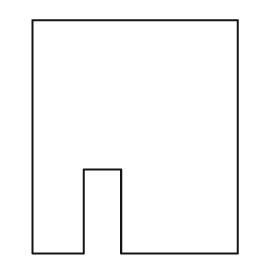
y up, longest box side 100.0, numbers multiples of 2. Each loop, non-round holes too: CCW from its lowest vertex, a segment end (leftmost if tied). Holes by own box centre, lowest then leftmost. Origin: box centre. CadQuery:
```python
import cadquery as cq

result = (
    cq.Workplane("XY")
    .moveTo(-44.0, -50.0)
    .lineTo(-22.0, -50.0)
    .lineTo(-22.0, -14.0)
    .lineTo(-6.0, -14.0)
    .lineTo(-6.0, -50.0)
    .lineTo(44.0, -50.0)
    .lineTo(44.0, 50.0)
    .lineTo(-44.0, 50.0)
    .close()
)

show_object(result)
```